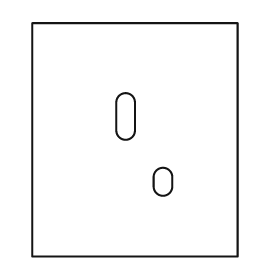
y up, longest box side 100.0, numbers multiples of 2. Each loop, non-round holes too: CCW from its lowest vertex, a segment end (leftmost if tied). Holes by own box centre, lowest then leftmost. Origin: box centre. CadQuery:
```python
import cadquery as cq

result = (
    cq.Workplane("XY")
    .moveTo(-44.0, -50.0)
    .lineTo(44.0, -50.0)
    .lineTo(44.0, 50.0)
    .lineTo(-44.0, 50.0)
    .close()
    .moveTo(8.0, -20.0)
    .threePointArc((12.0, -24.0), (16.0, -20.0))
    .lineTo(16.0, -16.0)
    .threePointArc((12.0, -12.0), (8.0, -16.0))
    .close()
    .moveTo(-8.0, 4.0)
    .threePointArc((-4.0, 0.0), (0.0, 4.0))
    .lineTo(0.0, 16.0)
    .threePointArc((-4.0, 20.0), (-8.0, 16.0))
    .close()
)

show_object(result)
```